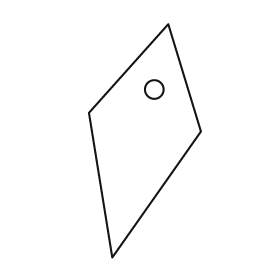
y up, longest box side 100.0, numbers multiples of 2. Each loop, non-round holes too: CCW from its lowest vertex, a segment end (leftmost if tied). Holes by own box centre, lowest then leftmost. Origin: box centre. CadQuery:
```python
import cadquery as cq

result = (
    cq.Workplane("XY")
    .moveTo(-14.0, -50.0)
    .lineTo(24.0, 4.0)
    .lineTo(10.0, 50.0)
    .lineTo(-24.0, 12.0)
    .close()
    .moveTo(4.0, 22.0)
    .circle(4.0)
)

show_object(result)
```